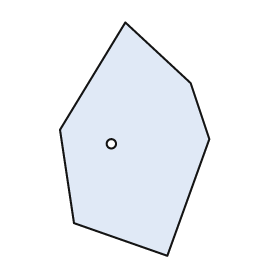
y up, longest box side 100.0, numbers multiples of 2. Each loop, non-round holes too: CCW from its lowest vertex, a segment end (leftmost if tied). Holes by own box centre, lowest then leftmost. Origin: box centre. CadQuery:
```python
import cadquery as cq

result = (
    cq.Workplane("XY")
    .moveTo(14.0, -50.0)
    .lineTo(32.0, 0.0)
    .lineTo(24.0, 24.0)
    .lineTo(-4.0, 50.0)
    .lineTo(-32.0, 4.0)
    .lineTo(-26.0, -36.0)
    .close()
    .moveTo(-10.0, -2.0)
    .circle(2.0)
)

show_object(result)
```